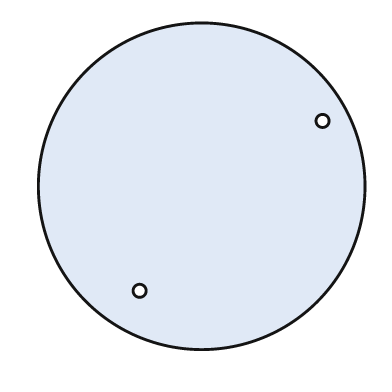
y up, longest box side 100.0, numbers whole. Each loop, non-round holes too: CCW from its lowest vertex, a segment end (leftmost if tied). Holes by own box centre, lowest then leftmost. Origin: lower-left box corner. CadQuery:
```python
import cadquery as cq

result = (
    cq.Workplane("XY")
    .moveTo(50.0, 50.0)
    .circle(50.0)
    .moveTo(31.0, 18.0)
    .circle(2.0)
    .moveTo(87.0, 70.0)
    .circle(2.0)
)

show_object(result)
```